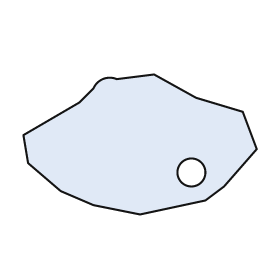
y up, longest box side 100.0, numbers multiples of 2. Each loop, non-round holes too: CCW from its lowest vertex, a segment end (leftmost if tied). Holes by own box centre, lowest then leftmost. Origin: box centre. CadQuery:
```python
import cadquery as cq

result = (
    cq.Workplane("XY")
    .moveTo(0.0, -30.0)
    .lineTo(28.0, -24.0)
    .lineTo(36.0, -18.0)
    .lineTo(50.0, -2.0)
    .lineTo(44.0, 14.0)
    .lineTo(24.0, 20.0)
    .lineTo(6.0, 30.0)
    .lineTo(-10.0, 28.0)
    .threePointArc((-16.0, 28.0), (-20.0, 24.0))
    .lineTo(-26.0, 18.0)
    .lineTo(-50.0, 4.0)
    .lineTo(-48.0, -8.0)
    .lineTo(-34.0, -20.0)
    .lineTo(-20.0, -26.0)
    .close()
    .moveTo(22.0, -12.0)
    .circle(6.0)
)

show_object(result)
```